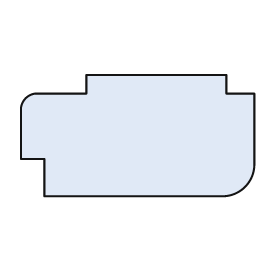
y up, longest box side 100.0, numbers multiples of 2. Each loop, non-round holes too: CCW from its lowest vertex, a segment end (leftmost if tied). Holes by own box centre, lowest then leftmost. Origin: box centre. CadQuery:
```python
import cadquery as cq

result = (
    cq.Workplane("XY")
    .moveTo(-40.0, -26.0)
    .lineTo(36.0, -26.0)
    .threePointArc((46.0, -22.0), (50.0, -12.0))
    .lineTo(50.0, 18.0)
    .lineTo(38.0, 18.0)
    .lineTo(38.0, 26.0)
    .lineTo(-22.0, 26.0)
    .lineTo(-22.0, 18.0)
    .lineTo(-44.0, 18.0)
    .threePointArc((-48.0, 16.0), (-50.0, 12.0))
    .lineTo(-50.0, -10.0)
    .lineTo(-40.0, -10.0)
    .close()
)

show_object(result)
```